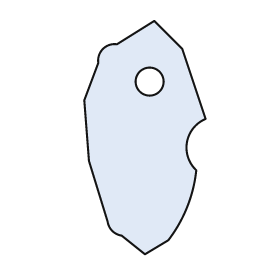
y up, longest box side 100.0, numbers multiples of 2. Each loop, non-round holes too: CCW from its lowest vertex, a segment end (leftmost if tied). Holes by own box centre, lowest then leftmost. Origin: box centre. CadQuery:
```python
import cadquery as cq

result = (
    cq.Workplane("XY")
    .moveTo(0.0, -50.0)
    .lineTo(10.0, -44.0)
    .threePointArc((18.0, -30.0), (22.0, -14.0))
    .threePointArc((18.0, -2.0), (26.0, 8.0))
    .lineTo(16.0, 38.0)
    .lineTo(4.0, 50.0)
    .lineTo(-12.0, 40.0)
    .threePointArc((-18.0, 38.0), (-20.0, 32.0))
    .lineTo(-26.0, 16.0)
    .lineTo(-24.0, -10.0)
    .lineTo(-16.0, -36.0)
    .threePointArc((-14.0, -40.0), (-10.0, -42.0))
    .close()
    .moveTo(2.0, 24.0)
    .circle(6.0)
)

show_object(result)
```